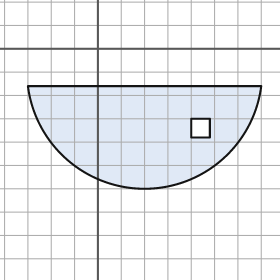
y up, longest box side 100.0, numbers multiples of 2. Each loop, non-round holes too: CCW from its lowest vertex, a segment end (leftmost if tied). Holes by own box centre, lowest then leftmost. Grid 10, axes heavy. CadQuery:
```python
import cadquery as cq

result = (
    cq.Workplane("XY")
    .moveTo(-30.0, -16.0)
    .threePointArc((20.0, -60.0), (70.0, -16.0))
    .close()
    .moveTo(40.0, -38.0)
    .lineTo(48.0, -38.0)
    .lineTo(48.0, -30.0)
    .lineTo(40.0, -30.0)
    .close()
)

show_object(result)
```